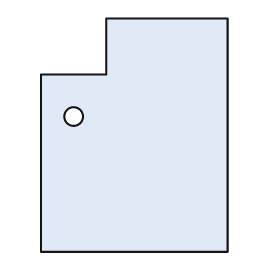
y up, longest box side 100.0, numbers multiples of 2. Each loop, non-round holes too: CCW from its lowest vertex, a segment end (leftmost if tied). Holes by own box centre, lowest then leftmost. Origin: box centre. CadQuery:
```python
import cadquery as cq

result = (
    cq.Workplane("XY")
    .moveTo(-40.0, -50.0)
    .lineTo(40.0, -50.0)
    .lineTo(40.0, 50.0)
    .lineTo(-12.0, 50.0)
    .lineTo(-12.0, 26.0)
    .lineTo(-40.0, 26.0)
    .close()
    .moveTo(-26.0, 8.0)
    .circle(4.0)
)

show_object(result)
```